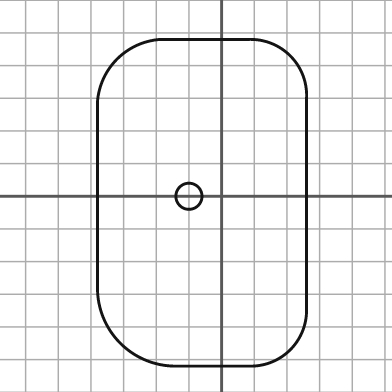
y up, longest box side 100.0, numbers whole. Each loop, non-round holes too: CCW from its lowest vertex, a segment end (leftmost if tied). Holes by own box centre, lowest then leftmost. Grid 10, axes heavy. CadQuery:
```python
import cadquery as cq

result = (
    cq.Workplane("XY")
    .moveTo(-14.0, -52.0)
    .lineTo(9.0, -52.0)
    .threePointArc((21.0, -47.0), (26.0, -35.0))
    .lineTo(26.0, 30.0)
    .threePointArc((21.0, 43.0), (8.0, 48.0))
    .lineTo(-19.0, 48.0)
    .threePointArc((-32.0, 42.0), (-38.0, 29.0))
    .lineTo(-38.0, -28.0)
    .threePointArc((-31.0, -45.0), (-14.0, -52.0))
    .close()
    .moveTo(-10.0, 0.0)
    .circle(4.0)
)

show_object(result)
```